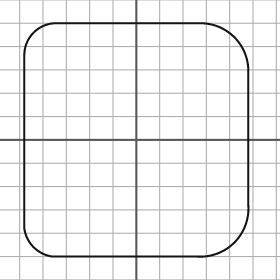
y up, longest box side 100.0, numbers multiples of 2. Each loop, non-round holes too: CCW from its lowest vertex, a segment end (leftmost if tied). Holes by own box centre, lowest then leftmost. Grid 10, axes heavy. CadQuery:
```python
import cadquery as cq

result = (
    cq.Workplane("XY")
    .moveTo(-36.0, -50.0)
    .lineTo(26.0, -50.0)
    .threePointArc((42.0, -44.0), (48.0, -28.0))
    .lineTo(48.0, 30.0)
    .threePointArc((42.0, 44.0), (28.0, 50.0))
    .lineTo(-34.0, 50.0)
    .threePointArc((-44.0, 46.0), (-48.0, 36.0))
    .lineTo(-48.0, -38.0)
    .threePointArc((-44.0, -46.0), (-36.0, -50.0))
    .close()
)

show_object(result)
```